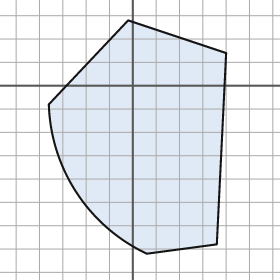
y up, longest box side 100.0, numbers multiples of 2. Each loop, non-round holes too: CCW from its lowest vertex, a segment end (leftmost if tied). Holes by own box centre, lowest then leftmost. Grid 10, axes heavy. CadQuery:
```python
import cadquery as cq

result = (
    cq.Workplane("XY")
    .moveTo(6.0, -72.0)
    .lineTo(36.0, -68.0)
    .lineTo(40.0, 14.0)
    .lineTo(-2.0, 28.0)
    .lineTo(-36.0, -8.0)
    .threePointArc((-24.0, -46.0), (6.0, -72.0))
    .close()
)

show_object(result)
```